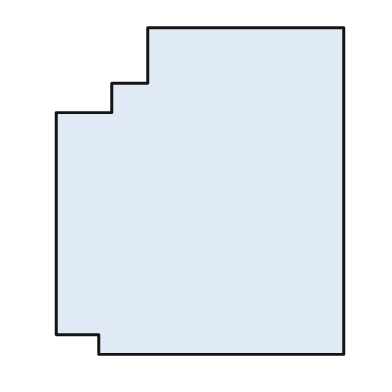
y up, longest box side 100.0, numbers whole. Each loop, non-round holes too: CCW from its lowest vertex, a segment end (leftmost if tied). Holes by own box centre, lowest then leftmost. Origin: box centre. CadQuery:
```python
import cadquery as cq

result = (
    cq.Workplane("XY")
    .moveTo(-31.0, -50.0)
    .lineTo(44.0, -50.0)
    .lineTo(44.0, 50.0)
    .lineTo(-16.0, 50.0)
    .lineTo(-16.0, 33.0)
    .lineTo(-27.0, 33.0)
    .lineTo(-27.0, 24.0)
    .lineTo(-44.0, 24.0)
    .lineTo(-44.0, -44.0)
    .lineTo(-31.0, -44.0)
    .close()
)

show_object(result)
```